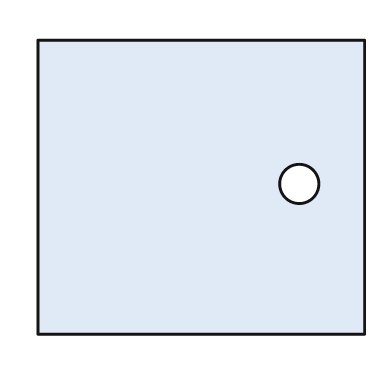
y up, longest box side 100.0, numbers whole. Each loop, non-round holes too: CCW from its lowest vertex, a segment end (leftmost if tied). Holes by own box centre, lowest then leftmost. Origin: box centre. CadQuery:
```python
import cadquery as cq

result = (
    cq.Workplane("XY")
    .moveTo(-50.0, -45.0)
    .lineTo(50.0, -45.0)
    .lineTo(50.0, 45.0)
    .lineTo(-50.0, 45.0)
    .close()
    .moveTo(30.0, 1.0)
    .circle(6.0)
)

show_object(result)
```